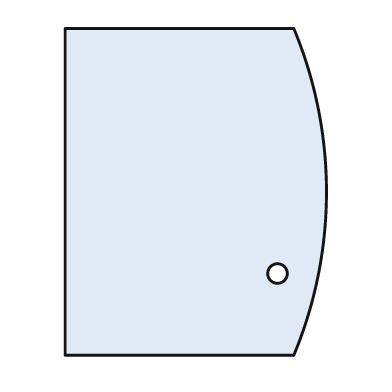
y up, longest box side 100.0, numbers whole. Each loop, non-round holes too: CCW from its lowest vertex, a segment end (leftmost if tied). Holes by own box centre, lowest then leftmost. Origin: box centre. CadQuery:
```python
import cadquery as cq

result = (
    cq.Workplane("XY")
    .moveTo(-40.0, -50.0)
    .lineTo(30.0, -50.0)
    .threePointArc((40.0, 0.0), (30.0, 50.0))
    .lineTo(-40.0, 50.0)
    .close()
    .moveTo(25.0, -25.0)
    .circle(3.0)
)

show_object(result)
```